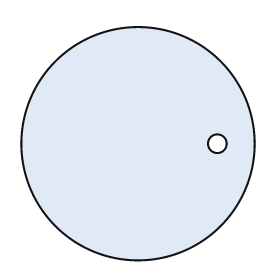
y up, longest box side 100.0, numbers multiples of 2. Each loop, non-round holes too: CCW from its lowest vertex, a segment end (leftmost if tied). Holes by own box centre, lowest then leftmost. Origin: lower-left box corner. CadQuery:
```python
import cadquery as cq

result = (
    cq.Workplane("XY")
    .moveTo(50.0, 50.0)
    .circle(50.0)
    .moveTo(84.0, 50.0)
    .circle(4.0)
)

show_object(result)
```